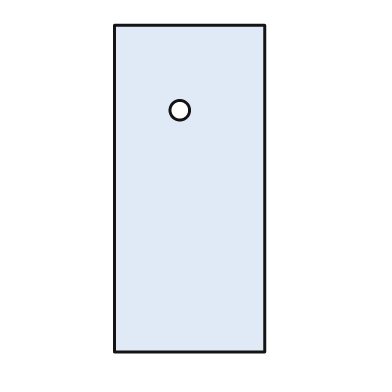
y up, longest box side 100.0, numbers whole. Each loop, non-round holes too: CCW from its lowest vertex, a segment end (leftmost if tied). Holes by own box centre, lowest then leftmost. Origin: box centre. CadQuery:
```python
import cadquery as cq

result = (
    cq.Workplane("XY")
    .moveTo(-23.0, -50.0)
    .lineTo(23.0, -50.0)
    .lineTo(23.0, 50.0)
    .lineTo(-23.0, 50.0)
    .close()
    .moveTo(-3.0, 24.0)
    .circle(3.0)
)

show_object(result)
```